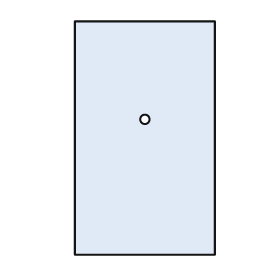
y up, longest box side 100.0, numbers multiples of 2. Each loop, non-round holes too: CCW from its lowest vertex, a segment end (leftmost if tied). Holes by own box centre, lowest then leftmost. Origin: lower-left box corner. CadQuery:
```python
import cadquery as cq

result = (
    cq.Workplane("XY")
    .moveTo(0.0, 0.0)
    .lineTo(60.0, 0.0)
    .lineTo(60.0, 100.0)
    .lineTo(0.0, 100.0)
    .close()
    .moveTo(30.0, 58.0)
    .circle(2.0)
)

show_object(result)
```